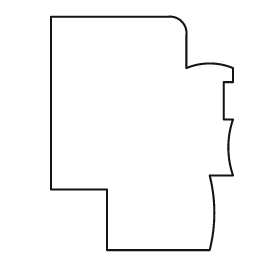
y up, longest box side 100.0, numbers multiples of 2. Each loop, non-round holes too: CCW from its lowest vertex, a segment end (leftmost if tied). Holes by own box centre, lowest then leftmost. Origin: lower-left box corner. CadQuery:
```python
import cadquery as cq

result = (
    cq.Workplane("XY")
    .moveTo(24.0, 0.0)
    .lineTo(68.0, 0.0)
    .threePointArc((70.0, 16.0), (68.0, 32.0))
    .lineTo(78.0, 32.0)
    .threePointArc((76.0, 44.0), (78.0, 56.0))
    .lineTo(74.0, 56.0)
    .lineTo(74.0, 72.0)
    .lineTo(78.0, 72.0)
    .lineTo(78.0, 78.0)
    .threePointArc((68.0, 80.0), (58.0, 78.0))
    .lineTo(58.0, 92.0)
    .threePointArc((56.0, 98.0), (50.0, 100.0))
    .lineTo(0.0, 100.0)
    .lineTo(0.0, 26.0)
    .lineTo(24.0, 26.0)
    .close()
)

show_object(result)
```